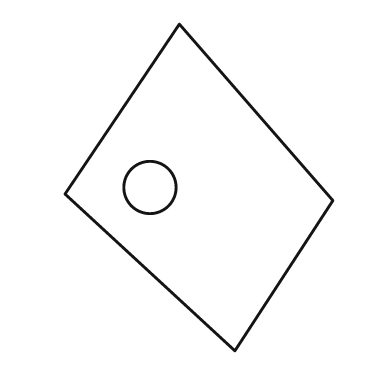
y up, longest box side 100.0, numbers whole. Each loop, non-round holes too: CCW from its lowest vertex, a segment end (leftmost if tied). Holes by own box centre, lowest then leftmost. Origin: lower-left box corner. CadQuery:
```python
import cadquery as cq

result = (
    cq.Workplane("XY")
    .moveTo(52.0, 0.0)
    .lineTo(82.0, 46.0)
    .lineTo(35.0, 100.0)
    .lineTo(0.0, 48.0)
    .close()
    .moveTo(26.0, 50.0)
    .circle(8.0)
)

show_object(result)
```